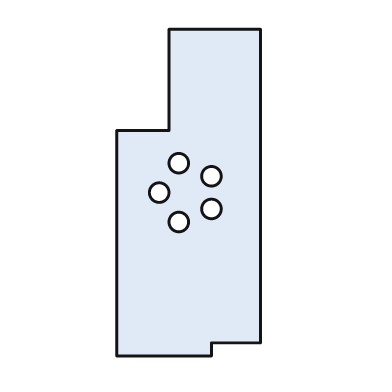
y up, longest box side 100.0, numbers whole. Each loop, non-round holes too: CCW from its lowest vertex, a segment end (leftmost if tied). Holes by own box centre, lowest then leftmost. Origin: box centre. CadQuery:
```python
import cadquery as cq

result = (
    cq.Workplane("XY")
    .moveTo(-22.0, -50.0)
    .lineTo(7.0, -50.0)
    .lineTo(7.0, -46.0)
    .lineTo(22.0, -46.0)
    .lineTo(22.0, 50.0)
    .lineTo(-6.0, 50.0)
    .lineTo(-6.0, 19.0)
    .lineTo(-22.0, 19.0)
    .close()
    .moveTo(-3.0, -9.0)
    .circle(3.0)
    .moveTo(7.0, -5.0)
    .circle(3.0)
    .moveTo(-9.0, 0.0)
    .circle(3.0)
    .moveTo(7.0, 5.0)
    .circle(3.0)
    .moveTo(-3.0, 9.0)
    .circle(3.0)
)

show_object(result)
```